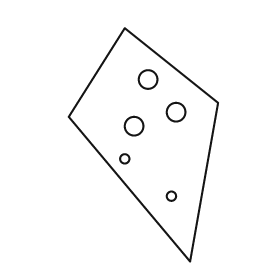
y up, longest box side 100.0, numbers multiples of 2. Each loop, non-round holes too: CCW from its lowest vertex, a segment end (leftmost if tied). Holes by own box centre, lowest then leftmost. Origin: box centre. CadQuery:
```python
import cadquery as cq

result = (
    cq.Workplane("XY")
    .moveTo(20.0, -50.0)
    .lineTo(32.0, 18.0)
    .lineTo(-8.0, 50.0)
    .lineTo(-32.0, 12.0)
    .close()
    .moveTo(12.0, -22.0)
    .circle(2.0)
    .moveTo(-8.0, -6.0)
    .circle(2.0)
    .moveTo(-4.0, 8.0)
    .circle(4.0)
    .moveTo(14.0, 14.0)
    .circle(4.0)
    .moveTo(2.0, 28.0)
    .circle(4.0)
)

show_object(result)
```